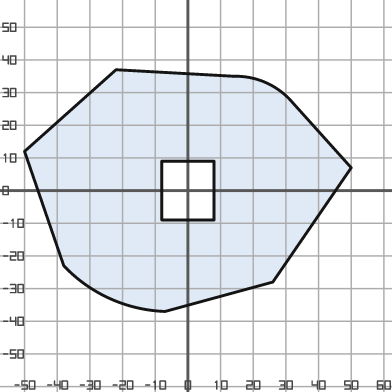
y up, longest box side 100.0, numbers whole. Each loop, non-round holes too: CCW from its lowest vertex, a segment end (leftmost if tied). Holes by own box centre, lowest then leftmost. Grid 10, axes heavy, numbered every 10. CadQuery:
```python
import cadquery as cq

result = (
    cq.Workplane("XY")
    .moveTo(-7.0, -37.0)
    .lineTo(26.0, -28.0)
    .lineTo(50.0, 7.0)
    .lineTo(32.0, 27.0)
    .threePointArc((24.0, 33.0), (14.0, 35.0))
    .lineTo(-22.0, 37.0)
    .lineTo(-50.0, 12.0)
    .lineTo(-38.0, -23.0)
    .threePointArc((-24.0, -33.0), (-7.0, -37.0))
    .close()
    .moveTo(-8.0, -9.0)
    .lineTo(8.0, -9.0)
    .lineTo(8.0, 9.0)
    .lineTo(-8.0, 9.0)
    .close()
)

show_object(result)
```